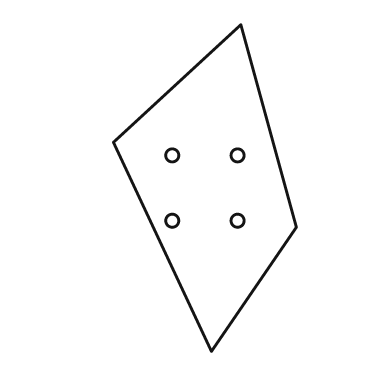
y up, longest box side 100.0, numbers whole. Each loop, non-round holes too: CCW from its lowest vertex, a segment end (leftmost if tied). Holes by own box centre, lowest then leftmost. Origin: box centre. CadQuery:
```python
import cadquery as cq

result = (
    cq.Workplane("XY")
    .moveTo(2.0, -50.0)
    .lineTo(28.0, -12.0)
    .lineTo(11.0, 50.0)
    .lineTo(-28.0, 14.0)
    .close()
    .moveTo(-10.0, -10.0)
    .circle(2.0)
    .moveTo(10.0, -10.0)
    .circle(2.0)
    .moveTo(-10.0, 10.0)
    .circle(2.0)
    .moveTo(10.0, 10.0)
    .circle(2.0)
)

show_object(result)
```